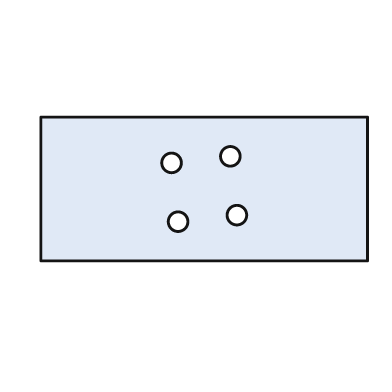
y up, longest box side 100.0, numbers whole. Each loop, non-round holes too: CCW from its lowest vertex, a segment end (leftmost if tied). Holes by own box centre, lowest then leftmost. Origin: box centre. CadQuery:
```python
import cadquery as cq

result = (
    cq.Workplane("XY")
    .moveTo(-50.0, -22.0)
    .lineTo(50.0, -22.0)
    .lineTo(50.0, 22.0)
    .lineTo(-50.0, 22.0)
    .close()
    .moveTo(-8.0, -10.0)
    .circle(3.0)
    .moveTo(10.0, -8.0)
    .circle(3.0)
    .moveTo(-10.0, 8.0)
    .circle(3.0)
    .moveTo(8.0, 10.0)
    .circle(3.0)
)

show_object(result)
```